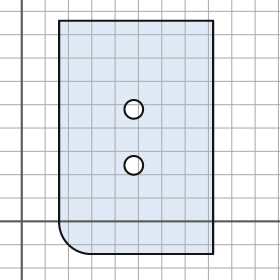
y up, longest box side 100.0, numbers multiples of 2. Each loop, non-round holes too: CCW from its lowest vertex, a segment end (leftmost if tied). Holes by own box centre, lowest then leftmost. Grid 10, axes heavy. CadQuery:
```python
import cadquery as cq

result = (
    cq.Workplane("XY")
    .moveTo(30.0, -14.0)
    .lineTo(82.0, -14.0)
    .lineTo(82.0, 86.0)
    .lineTo(16.0, 86.0)
    .lineTo(16.0, 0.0)
    .threePointArc((20.0, -10.0), (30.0, -14.0))
    .close()
    .moveTo(48.0, 24.0)
    .circle(4.0)
    .moveTo(48.0, 48.0)
    .circle(4.0)
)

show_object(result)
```